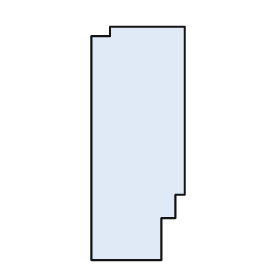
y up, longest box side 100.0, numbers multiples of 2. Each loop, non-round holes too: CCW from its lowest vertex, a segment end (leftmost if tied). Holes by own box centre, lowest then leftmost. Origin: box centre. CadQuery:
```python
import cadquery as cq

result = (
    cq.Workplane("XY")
    .moveTo(-20.0, -50.0)
    .lineTo(10.0, -50.0)
    .lineTo(10.0, -32.0)
    .lineTo(16.0, -32.0)
    .lineTo(16.0, -22.0)
    .lineTo(20.0, -22.0)
    .lineTo(20.0, 50.0)
    .lineTo(-12.0, 50.0)
    .lineTo(-12.0, 46.0)
    .lineTo(-20.0, 46.0)
    .close()
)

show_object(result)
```